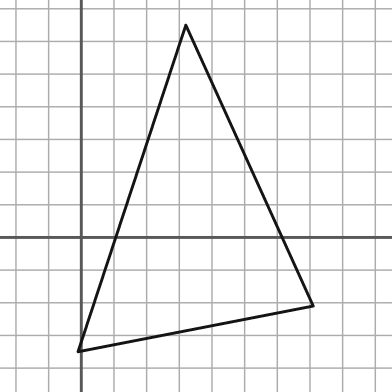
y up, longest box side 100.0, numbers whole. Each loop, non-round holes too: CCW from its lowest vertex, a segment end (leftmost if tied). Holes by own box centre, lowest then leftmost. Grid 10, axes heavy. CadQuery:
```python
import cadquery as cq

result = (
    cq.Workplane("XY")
    .moveTo(-1.0, -35.0)
    .lineTo(71.0, -21.0)
    .lineTo(32.0, 65.0)
    .close()
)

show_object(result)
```